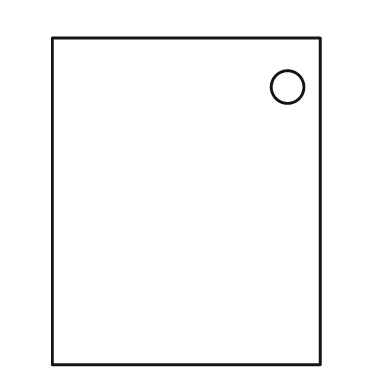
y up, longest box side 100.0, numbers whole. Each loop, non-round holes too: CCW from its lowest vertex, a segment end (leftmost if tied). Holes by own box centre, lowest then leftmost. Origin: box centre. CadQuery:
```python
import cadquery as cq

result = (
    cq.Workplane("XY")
    .moveTo(-41.0, -50.0)
    .lineTo(41.0, -50.0)
    .lineTo(41.0, 50.0)
    .lineTo(-41.0, 50.0)
    .close()
    .moveTo(31.0, 35.0)
    .circle(5.0)
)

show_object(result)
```